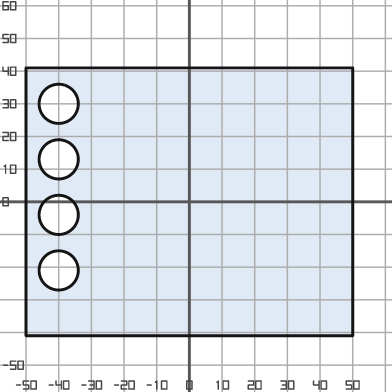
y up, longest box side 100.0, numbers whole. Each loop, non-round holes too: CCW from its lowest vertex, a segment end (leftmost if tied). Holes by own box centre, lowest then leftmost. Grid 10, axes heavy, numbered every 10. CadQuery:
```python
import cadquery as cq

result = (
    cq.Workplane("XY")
    .moveTo(-50.0, -41.0)
    .lineTo(50.0, -41.0)
    .lineTo(50.0, 41.0)
    .lineTo(-50.0, 41.0)
    .close()
    .moveTo(-40.0, -21.0)
    .circle(6.0)
    .moveTo(-40.0, -4.0)
    .circle(6.0)
    .moveTo(-40.0, 13.0)
    .circle(6.0)
    .moveTo(-40.0, 30.0)
    .circle(6.0)
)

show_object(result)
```